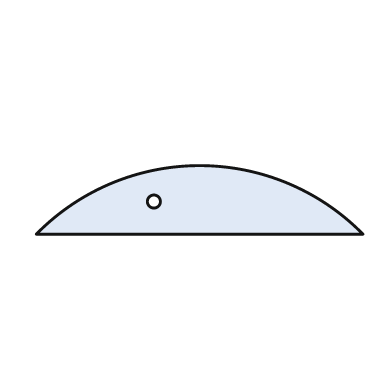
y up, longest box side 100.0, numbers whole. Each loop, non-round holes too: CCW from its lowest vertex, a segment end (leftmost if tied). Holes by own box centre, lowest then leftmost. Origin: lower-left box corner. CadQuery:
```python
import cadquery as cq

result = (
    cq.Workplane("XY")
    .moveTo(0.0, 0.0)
    .lineTo(100.0, 0.0)
    .threePointArc((50.0, 21.0), (0.0, 0.0))
    .close()
    .moveTo(36.0, 10.0)
    .circle(2.0)
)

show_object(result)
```